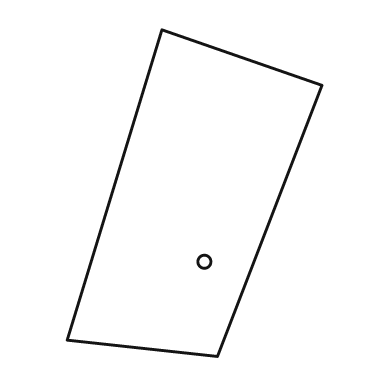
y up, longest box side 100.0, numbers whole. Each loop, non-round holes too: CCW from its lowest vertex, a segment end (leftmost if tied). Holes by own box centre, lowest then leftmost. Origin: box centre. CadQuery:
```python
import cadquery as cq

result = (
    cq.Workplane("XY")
    .moveTo(7.0, -50.0)
    .lineTo(39.0, 33.0)
    .lineTo(-10.0, 50.0)
    .lineTo(-39.0, -45.0)
    .close()
    .moveTo(3.0, -21.0)
    .circle(2.0)
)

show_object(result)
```